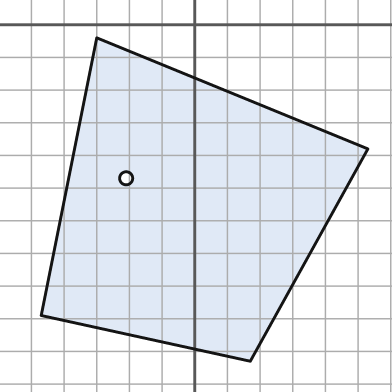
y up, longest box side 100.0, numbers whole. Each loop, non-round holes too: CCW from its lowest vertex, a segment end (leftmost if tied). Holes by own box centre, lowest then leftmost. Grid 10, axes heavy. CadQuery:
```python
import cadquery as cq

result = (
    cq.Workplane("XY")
    .moveTo(17.0, -103.0)
    .lineTo(53.0, -38.0)
    .lineTo(-30.0, -4.0)
    .lineTo(-47.0, -89.0)
    .close()
    .moveTo(-21.0, -47.0)
    .circle(2.0)
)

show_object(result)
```